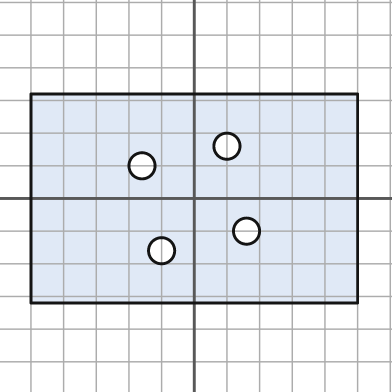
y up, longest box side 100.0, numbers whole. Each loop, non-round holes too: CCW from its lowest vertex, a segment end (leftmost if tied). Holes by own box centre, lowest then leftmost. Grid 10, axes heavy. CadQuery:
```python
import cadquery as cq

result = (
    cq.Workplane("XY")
    .moveTo(-50.0, -32.0)
    .lineTo(50.0, -32.0)
    .lineTo(50.0, 32.0)
    .lineTo(-50.0, 32.0)
    .close()
    .moveTo(-10.0, -16.0)
    .circle(4.0)
    .moveTo(16.0, -10.0)
    .circle(4.0)
    .moveTo(-16.0, 10.0)
    .circle(4.0)
    .moveTo(10.0, 16.0)
    .circle(4.0)
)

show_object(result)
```